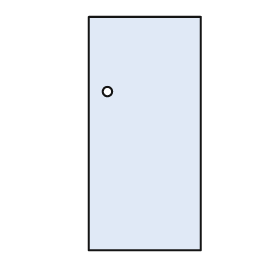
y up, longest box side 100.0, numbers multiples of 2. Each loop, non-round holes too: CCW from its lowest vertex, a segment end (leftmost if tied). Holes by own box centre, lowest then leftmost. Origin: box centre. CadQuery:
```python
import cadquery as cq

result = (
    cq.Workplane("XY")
    .moveTo(-24.0, -50.0)
    .lineTo(24.0, -50.0)
    .lineTo(24.0, 50.0)
    .lineTo(-24.0, 50.0)
    .close()
    .moveTo(-16.0, 18.0)
    .circle(2.0)
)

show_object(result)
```